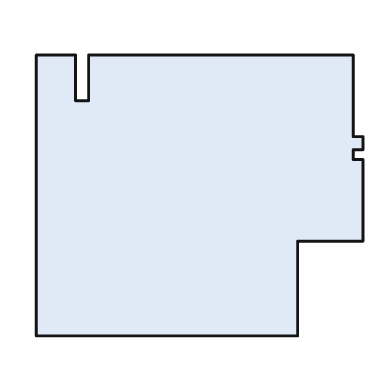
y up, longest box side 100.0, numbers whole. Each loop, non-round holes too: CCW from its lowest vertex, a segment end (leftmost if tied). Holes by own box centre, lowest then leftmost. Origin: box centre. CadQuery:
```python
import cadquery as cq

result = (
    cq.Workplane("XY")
    .moveTo(-50.0, -43.0)
    .lineTo(30.0, -43.0)
    .lineTo(30.0, -14.0)
    .lineTo(50.0, -14.0)
    .lineTo(50.0, 11.0)
    .lineTo(47.0, 11.0)
    .lineTo(47.0, 14.0)
    .lineTo(50.0, 14.0)
    .lineTo(50.0, 18.0)
    .lineTo(47.0, 18.0)
    .lineTo(47.0, 43.0)
    .lineTo(-34.0, 43.0)
    .lineTo(-34.0, 29.0)
    .lineTo(-38.0, 29.0)
    .lineTo(-38.0, 43.0)
    .lineTo(-50.0, 43.0)
    .close()
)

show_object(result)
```